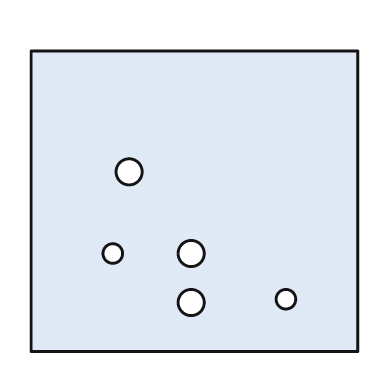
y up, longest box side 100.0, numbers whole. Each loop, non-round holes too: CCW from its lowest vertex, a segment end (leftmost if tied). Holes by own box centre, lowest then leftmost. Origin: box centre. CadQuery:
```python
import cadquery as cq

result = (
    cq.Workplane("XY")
    .moveTo(-50.0, -46.0)
    .lineTo(50.0, -46.0)
    .lineTo(50.0, 46.0)
    .lineTo(-50.0, 46.0)
    .close()
    .moveTo(-1.0, -31.0)
    .circle(4.0)
    .moveTo(28.0, -30.0)
    .circle(3.0)
    .moveTo(-25.0, -16.0)
    .circle(3.0)
    .moveTo(-1.0, -16.0)
    .circle(4.0)
    .moveTo(-20.0, 9.0)
    .circle(4.0)
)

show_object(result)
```